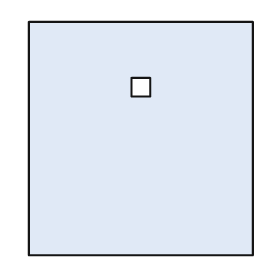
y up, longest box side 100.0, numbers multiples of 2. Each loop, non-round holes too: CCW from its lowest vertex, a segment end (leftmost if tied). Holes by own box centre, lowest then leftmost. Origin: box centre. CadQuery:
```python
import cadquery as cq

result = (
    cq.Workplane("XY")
    .moveTo(-48.0, -50.0)
    .lineTo(48.0, -50.0)
    .lineTo(48.0, 50.0)
    .lineTo(-48.0, 50.0)
    .close()
    .moveTo(-4.0, 18.0)
    .lineTo(4.0, 18.0)
    .lineTo(4.0, 26.0)
    .lineTo(-4.0, 26.0)
    .close()
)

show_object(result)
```